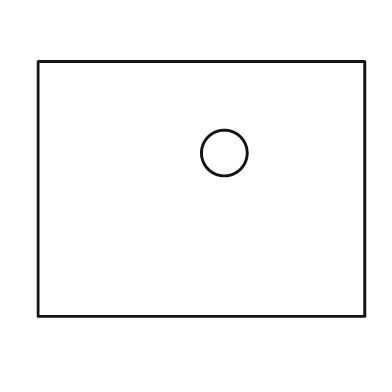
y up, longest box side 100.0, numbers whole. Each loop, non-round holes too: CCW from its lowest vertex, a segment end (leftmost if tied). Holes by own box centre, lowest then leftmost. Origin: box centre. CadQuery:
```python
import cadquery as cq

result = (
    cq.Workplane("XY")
    .moveTo(-50.0, -39.0)
    .lineTo(50.0, -39.0)
    .lineTo(50.0, 39.0)
    .lineTo(-50.0, 39.0)
    .close()
    .moveTo(7.0, 11.0)
    .circle(7.0)
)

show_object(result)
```